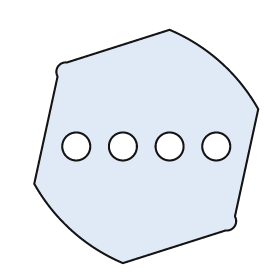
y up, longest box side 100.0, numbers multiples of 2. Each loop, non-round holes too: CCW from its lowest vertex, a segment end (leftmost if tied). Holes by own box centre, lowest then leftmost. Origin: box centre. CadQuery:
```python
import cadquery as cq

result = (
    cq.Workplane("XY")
    .moveTo(-10.0, -50.0)
    .lineTo(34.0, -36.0)
    .threePointArc((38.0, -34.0), (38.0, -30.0))
    .lineTo(48.0, 16.0)
    .threePointArc((32.0, 36.0), (10.0, 50.0))
    .lineTo(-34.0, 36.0)
    .threePointArc((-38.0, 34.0), (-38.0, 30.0))
    .lineTo(-48.0, -16.0)
    .threePointArc((-32.0, -36.0), (-10.0, -50.0))
    .close()
    .moveTo(-30.0, 0.0)
    .circle(6.0)
    .moveTo(-10.0, 0.0)
    .circle(6.0)
    .moveTo(10.0, 0.0)
    .circle(6.0)
    .moveTo(30.0, 0.0)
    .circle(6.0)
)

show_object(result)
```